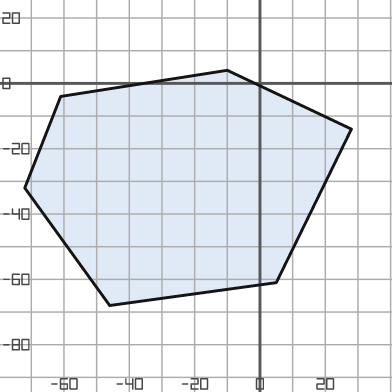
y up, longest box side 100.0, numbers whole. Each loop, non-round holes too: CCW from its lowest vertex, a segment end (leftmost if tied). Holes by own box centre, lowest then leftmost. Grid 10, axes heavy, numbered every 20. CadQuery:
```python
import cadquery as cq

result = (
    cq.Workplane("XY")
    .moveTo(-46.0, -68.0)
    .lineTo(5.0, -61.0)
    .lineTo(28.0, -14.0)
    .lineTo(-10.0, 4.0)
    .lineTo(-61.0, -4.0)
    .lineTo(-72.0, -32.0)
    .close()
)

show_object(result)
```